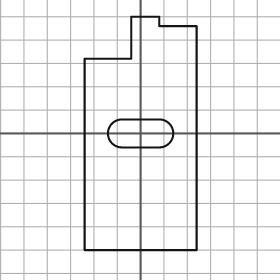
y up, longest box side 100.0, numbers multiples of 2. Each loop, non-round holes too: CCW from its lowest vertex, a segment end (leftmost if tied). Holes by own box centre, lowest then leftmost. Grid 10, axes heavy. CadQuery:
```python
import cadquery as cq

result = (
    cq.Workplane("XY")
    .moveTo(-24.0, -50.0)
    .lineTo(24.0, -50.0)
    .lineTo(24.0, 46.0)
    .lineTo(8.0, 46.0)
    .lineTo(8.0, 50.0)
    .lineTo(-4.0, 50.0)
    .lineTo(-4.0, 32.0)
    .lineTo(-24.0, 32.0)
    .close()
    .moveTo(-8.0, -6.0)
    .lineTo(8.0, -6.0)
    .threePointArc((14.0, 0.0), (8.0, 6.0))
    .lineTo(-8.0, 6.0)
    .threePointArc((-14.0, 0.0), (-8.0, -6.0))
    .close()
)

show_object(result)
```